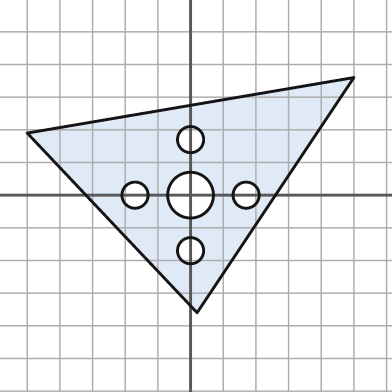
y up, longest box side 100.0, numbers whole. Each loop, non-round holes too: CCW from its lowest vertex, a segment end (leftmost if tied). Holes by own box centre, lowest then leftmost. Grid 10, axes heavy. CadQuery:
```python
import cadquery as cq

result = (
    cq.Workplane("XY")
    .moveTo(2.0, -36.0)
    .lineTo(50.0, 36.0)
    .lineTo(-50.0, 19.0)
    .close()
    .moveTo(0.0, -17.0)
    .circle(4.0)
    .moveTo(-17.0, 0.0)
    .circle(4.0)
    .moveTo(0.0, 0.0)
    .circle(7.0)
    .moveTo(17.0, 0.0)
    .circle(4.0)
    .moveTo(0.0, 17.0)
    .circle(4.0)
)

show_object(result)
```